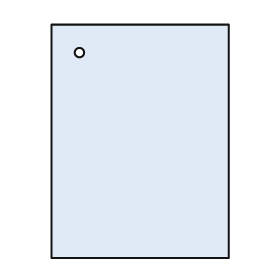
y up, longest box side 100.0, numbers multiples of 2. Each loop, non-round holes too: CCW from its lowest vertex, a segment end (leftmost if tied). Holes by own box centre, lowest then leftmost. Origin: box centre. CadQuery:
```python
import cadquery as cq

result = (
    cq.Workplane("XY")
    .moveTo(-38.0, -50.0)
    .lineTo(38.0, -50.0)
    .lineTo(38.0, 50.0)
    .lineTo(-38.0, 50.0)
    .close()
    .moveTo(-26.0, 38.0)
    .circle(2.0)
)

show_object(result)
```